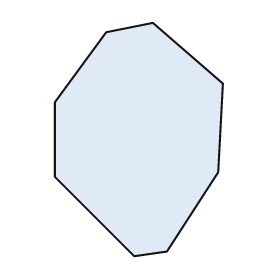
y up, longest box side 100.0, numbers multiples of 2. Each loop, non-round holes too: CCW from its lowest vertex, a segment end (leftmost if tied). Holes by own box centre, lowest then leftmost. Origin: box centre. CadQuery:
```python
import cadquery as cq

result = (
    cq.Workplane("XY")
    .moveTo(-2.0, -50.0)
    .lineTo(12.0, -48.0)
    .lineTo(34.0, -14.0)
    .lineTo(36.0, 24.0)
    .lineTo(6.0, 50.0)
    .lineTo(-14.0, 46.0)
    .lineTo(-36.0, 16.0)
    .lineTo(-36.0, -16.0)
    .close()
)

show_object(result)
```